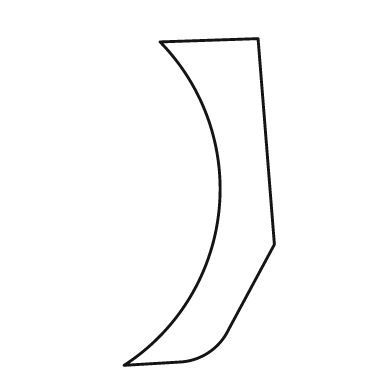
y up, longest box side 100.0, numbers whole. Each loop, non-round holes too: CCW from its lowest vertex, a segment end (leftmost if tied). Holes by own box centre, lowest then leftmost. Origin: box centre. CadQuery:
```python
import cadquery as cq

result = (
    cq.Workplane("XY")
    .moveTo(-23.0, -50.0)
    .lineTo(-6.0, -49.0)
    .threePointArc((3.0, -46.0), (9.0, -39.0))
    .lineTo(23.0, -13.0)
    .lineTo(18.0, 50.0)
    .lineTo(-12.0, 49.0)
    .threePointArc((6.0, -3.0), (-23.0, -50.0))
    .close()
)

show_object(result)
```